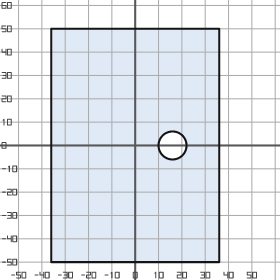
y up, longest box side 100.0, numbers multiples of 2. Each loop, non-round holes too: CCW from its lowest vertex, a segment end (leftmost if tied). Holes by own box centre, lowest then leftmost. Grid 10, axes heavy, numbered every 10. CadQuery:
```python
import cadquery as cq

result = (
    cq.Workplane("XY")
    .moveTo(-36.0, -50.0)
    .lineTo(36.0, -50.0)
    .lineTo(36.0, 50.0)
    .lineTo(-36.0, 50.0)
    .close()
    .moveTo(16.0, 0.0)
    .circle(6.0)
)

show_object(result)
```